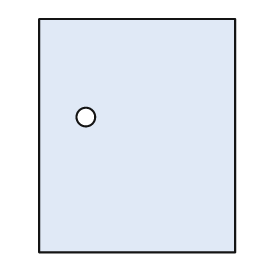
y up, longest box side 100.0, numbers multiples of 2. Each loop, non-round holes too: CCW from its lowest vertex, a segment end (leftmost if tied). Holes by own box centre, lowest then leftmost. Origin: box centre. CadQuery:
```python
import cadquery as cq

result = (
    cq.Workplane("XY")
    .moveTo(-42.0, -50.0)
    .lineTo(42.0, -50.0)
    .lineTo(42.0, 50.0)
    .lineTo(-42.0, 50.0)
    .close()
    .moveTo(-22.0, 8.0)
    .circle(4.0)
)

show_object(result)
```